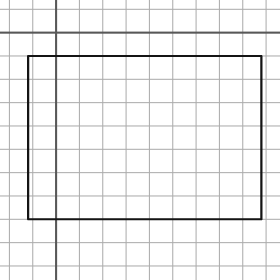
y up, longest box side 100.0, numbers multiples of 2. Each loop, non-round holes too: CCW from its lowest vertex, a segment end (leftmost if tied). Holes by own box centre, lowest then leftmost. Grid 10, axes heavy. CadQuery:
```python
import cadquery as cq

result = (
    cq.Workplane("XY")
    .moveTo(-12.0, -80.0)
    .lineTo(88.0, -80.0)
    .lineTo(88.0, -10.0)
    .lineTo(-12.0, -10.0)
    .close()
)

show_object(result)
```